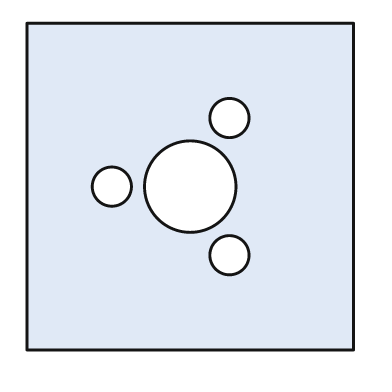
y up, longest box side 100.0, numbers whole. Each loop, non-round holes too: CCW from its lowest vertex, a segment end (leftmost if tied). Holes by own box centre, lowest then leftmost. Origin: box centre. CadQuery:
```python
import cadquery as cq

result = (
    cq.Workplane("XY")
    .moveTo(-50.0, -50.0)
    .lineTo(50.0, -50.0)
    .lineTo(50.0, 50.0)
    .lineTo(-50.0, 50.0)
    .close()
    .moveTo(12.0, -21.0)
    .circle(6.0)
    .moveTo(-24.0, 0.0)
    .circle(6.0)
    .moveTo(0.0, 0.0)
    .circle(14.0)
    .moveTo(12.0, 21.0)
    .circle(6.0)
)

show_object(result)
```